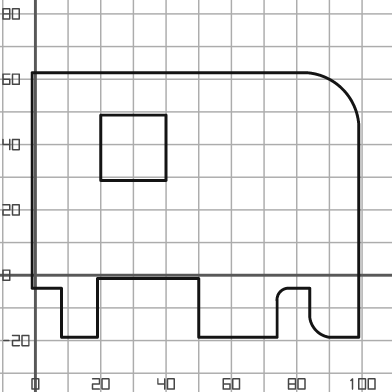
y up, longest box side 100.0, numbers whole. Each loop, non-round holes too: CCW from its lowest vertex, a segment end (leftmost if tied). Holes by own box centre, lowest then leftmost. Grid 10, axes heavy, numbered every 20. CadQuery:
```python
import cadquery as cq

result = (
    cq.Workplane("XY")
    .moveTo(8.0, -19.0)
    .lineTo(19.0, -19.0)
    .lineTo(19.0, -1.0)
    .lineTo(50.0, -1.0)
    .lineTo(50.0, -19.0)
    .lineTo(74.0, -19.0)
    .lineTo(74.0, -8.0)
    .threePointArc((75.0, -5.0), (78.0, -4.0))
    .lineTo(84.0, -4.0)
    .lineTo(84.0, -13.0)
    .threePointArc((86.0, -17.0), (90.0, -19.0))
    .lineTo(99.0, -19.0)
    .lineTo(99.0, 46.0)
    .threePointArc((94.0, 57.0), (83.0, 62.0))
    .lineTo(-1.0, 62.0)
    .lineTo(-1.0, -4.0)
    .lineTo(8.0, -4.0)
    .close()
    .moveTo(20.0, 29.0)
    .lineTo(40.0, 29.0)
    .lineTo(40.0, 49.0)
    .lineTo(20.0, 49.0)
    .close()
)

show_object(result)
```